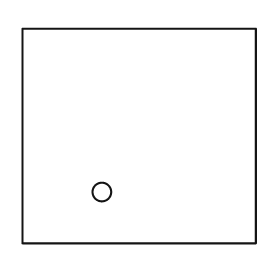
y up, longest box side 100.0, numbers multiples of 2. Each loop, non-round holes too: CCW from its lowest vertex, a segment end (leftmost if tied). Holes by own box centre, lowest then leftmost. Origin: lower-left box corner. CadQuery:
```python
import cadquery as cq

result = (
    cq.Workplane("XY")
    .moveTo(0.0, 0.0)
    .lineTo(100.0, 0.0)
    .lineTo(100.0, 92.0)
    .lineTo(0.0, 92.0)
    .close()
    .moveTo(34.0, 22.0)
    .circle(4.0)
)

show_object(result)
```